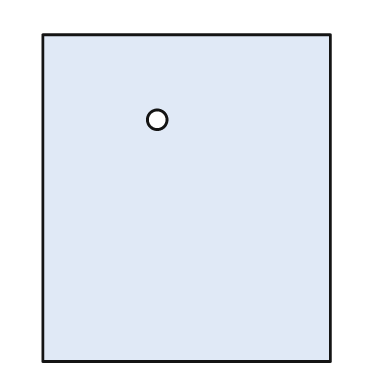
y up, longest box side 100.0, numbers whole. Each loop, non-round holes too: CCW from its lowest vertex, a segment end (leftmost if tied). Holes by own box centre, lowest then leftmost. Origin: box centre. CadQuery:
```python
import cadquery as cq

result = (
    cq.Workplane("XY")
    .moveTo(-44.0, -50.0)
    .lineTo(44.0, -50.0)
    .lineTo(44.0, 50.0)
    .lineTo(-44.0, 50.0)
    .close()
    .moveTo(-9.0, 24.0)
    .circle(3.0)
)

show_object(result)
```